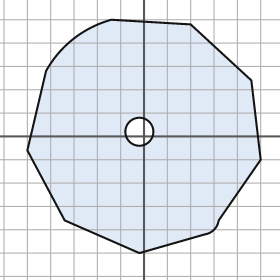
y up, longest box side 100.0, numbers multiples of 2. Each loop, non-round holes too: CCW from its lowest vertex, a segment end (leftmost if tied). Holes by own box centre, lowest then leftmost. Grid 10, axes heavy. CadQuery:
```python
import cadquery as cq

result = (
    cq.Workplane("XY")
    .moveTo(-2.0, -50.0)
    .lineTo(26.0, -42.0)
    .threePointArc((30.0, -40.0), (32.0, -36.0))
    .lineTo(50.0, -10.0)
    .lineTo(46.0, 24.0)
    .lineTo(20.0, 48.0)
    .lineTo(-14.0, 50.0)
    .threePointArc((-30.0, 42.0), (-42.0, 28.0))
    .lineTo(-50.0, -6.0)
    .lineTo(-34.0, -36.0)
    .close()
    .moveTo(-2.0, 2.0)
    .circle(6.0)
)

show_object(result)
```